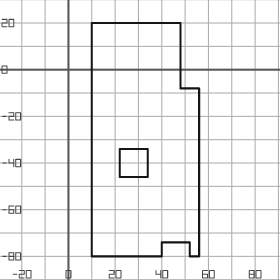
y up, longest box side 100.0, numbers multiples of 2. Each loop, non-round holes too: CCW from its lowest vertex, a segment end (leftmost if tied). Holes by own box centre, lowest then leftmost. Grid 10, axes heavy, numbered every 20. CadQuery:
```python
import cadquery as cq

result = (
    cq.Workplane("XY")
    .moveTo(10.0, -80.0)
    .lineTo(40.0, -80.0)
    .lineTo(40.0, -74.0)
    .lineTo(52.0, -74.0)
    .lineTo(52.0, -80.0)
    .lineTo(56.0, -80.0)
    .lineTo(56.0, -8.0)
    .lineTo(48.0, -8.0)
    .lineTo(48.0, 20.0)
    .lineTo(10.0, 20.0)
    .close()
    .moveTo(22.0, -46.0)
    .lineTo(34.0, -46.0)
    .lineTo(34.0, -34.0)
    .lineTo(22.0, -34.0)
    .close()
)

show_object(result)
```